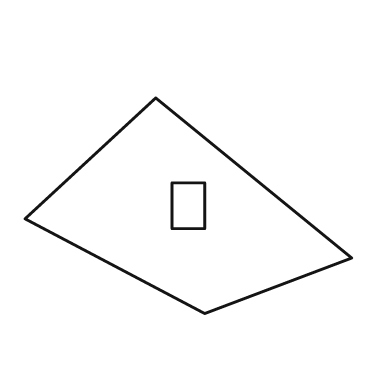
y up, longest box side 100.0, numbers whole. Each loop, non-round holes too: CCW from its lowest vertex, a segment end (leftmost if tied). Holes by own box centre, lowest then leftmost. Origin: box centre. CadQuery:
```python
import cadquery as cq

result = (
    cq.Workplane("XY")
    .moveTo(5.0, -33.0)
    .lineTo(50.0, -16.0)
    .lineTo(-10.0, 33.0)
    .lineTo(-50.0, -4.0)
    .close()
    .moveTo(-5.0, -7.0)
    .lineTo(5.0, -7.0)
    .lineTo(5.0, 7.0)
    .lineTo(-5.0, 7.0)
    .close()
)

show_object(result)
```